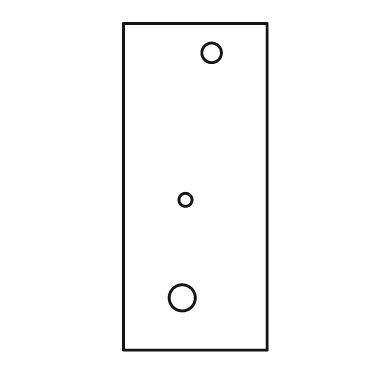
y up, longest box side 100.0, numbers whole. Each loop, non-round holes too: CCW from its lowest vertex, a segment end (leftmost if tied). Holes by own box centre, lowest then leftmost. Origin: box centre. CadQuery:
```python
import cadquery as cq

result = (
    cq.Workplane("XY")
    .moveTo(-22.0, -50.0)
    .lineTo(22.0, -50.0)
    .lineTo(22.0, 50.0)
    .lineTo(-22.0, 50.0)
    .close()
    .moveTo(-4.0, -34.0)
    .circle(4.0)
    .moveTo(-3.0, -4.0)
    .circle(2.0)
    .moveTo(5.0, 41.0)
    .circle(3.0)
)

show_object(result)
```